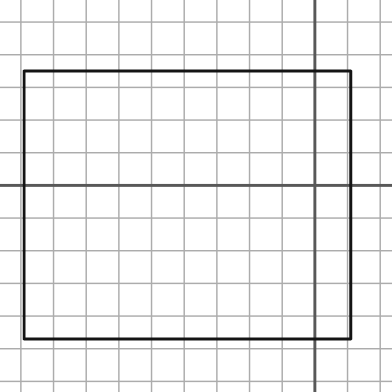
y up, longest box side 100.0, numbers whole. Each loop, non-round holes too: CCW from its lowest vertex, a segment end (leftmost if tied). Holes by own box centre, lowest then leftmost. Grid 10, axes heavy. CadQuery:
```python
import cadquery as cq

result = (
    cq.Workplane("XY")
    .moveTo(-89.0, -47.0)
    .lineTo(11.0, -47.0)
    .lineTo(11.0, 35.0)
    .lineTo(-89.0, 35.0)
    .close()
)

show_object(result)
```